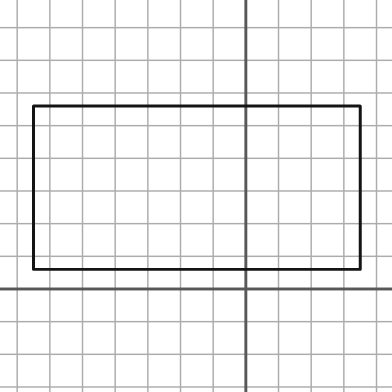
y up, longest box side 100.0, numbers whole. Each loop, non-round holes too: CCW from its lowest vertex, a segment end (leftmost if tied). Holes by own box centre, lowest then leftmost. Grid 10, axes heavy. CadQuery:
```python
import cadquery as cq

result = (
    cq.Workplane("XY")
    .moveTo(-65.0, 6.0)
    .lineTo(35.0, 6.0)
    .lineTo(35.0, 56.0)
    .lineTo(-65.0, 56.0)
    .close()
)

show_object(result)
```